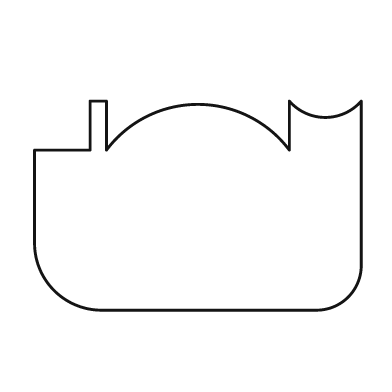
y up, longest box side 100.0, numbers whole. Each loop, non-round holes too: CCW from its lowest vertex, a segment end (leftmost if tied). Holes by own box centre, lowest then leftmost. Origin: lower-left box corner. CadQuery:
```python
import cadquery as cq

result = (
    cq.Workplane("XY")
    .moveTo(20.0, 0.0)
    .lineTo(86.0, 0.0)
    .threePointArc((96.0, 4.0), (100.0, 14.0))
    .lineTo(100.0, 64.0)
    .threePointArc((89.0, 59.0), (78.0, 64.0))
    .lineTo(78.0, 49.0)
    .threePointArc((50.0, 63.0), (22.0, 49.0))
    .lineTo(22.0, 64.0)
    .lineTo(17.0, 64.0)
    .lineTo(17.0, 49.0)
    .lineTo(0.0, 49.0)
    .lineTo(0.0, 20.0)
    .threePointArc((6.0, 6.0), (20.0, 0.0))
    .close()
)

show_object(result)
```